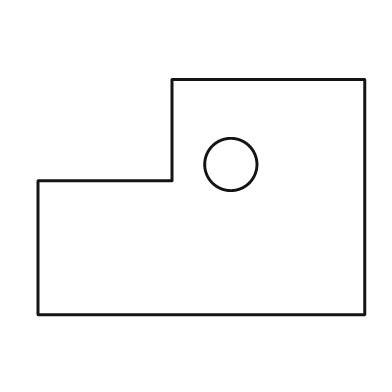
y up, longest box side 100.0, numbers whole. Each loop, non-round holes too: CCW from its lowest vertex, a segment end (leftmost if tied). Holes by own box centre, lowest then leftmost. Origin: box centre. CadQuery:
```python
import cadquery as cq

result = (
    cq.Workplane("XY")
    .moveTo(-50.0, -36.0)
    .lineTo(50.0, -36.0)
    .lineTo(50.0, 36.0)
    .lineTo(-9.0, 36.0)
    .lineTo(-9.0, 5.0)
    .lineTo(-50.0, 5.0)
    .close()
    .moveTo(9.0, 10.0)
    .circle(8.0)
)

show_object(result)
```